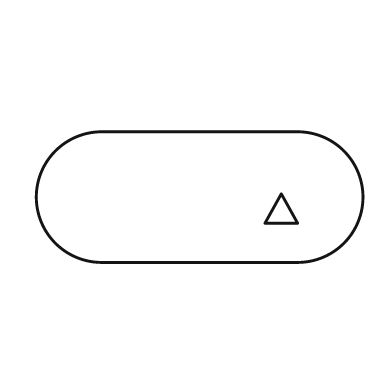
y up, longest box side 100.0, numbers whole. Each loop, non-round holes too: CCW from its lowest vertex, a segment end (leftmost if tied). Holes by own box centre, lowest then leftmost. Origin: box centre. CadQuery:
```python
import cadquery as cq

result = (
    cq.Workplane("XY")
    .moveTo(-30.0, -20.0)
    .lineTo(30.0, -20.0)
    .threePointArc((50.0, 0.0), (30.0, 20.0))
    .lineTo(-30.0, 20.0)
    .threePointArc((-50.0, 0.0), (-30.0, -20.0))
    .close()
    .moveTo(20.0, -8.0)
    .lineTo(30.0, -8.0)
    .lineTo(25.0, 1.0)
    .close()
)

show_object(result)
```